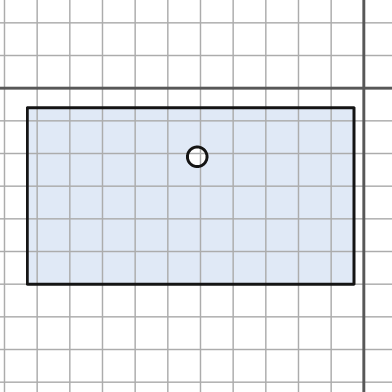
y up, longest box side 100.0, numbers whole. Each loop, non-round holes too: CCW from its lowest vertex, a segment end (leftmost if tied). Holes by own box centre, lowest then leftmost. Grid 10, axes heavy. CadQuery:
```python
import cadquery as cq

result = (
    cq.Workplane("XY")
    .moveTo(-103.0, -60.0)
    .lineTo(-3.0, -60.0)
    .lineTo(-3.0, -6.0)
    .lineTo(-103.0, -6.0)
    .close()
    .moveTo(-51.0, -21.0)
    .circle(3.0)
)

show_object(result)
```